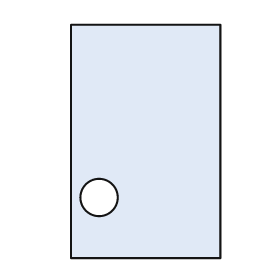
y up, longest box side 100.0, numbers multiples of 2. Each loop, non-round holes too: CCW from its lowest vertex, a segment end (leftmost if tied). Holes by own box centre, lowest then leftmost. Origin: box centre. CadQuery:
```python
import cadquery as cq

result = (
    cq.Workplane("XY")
    .moveTo(-32.0, -50.0)
    .lineTo(32.0, -50.0)
    .lineTo(32.0, 50.0)
    .lineTo(-32.0, 50.0)
    .close()
    .moveTo(-20.0, -24.0)
    .circle(8.0)
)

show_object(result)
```